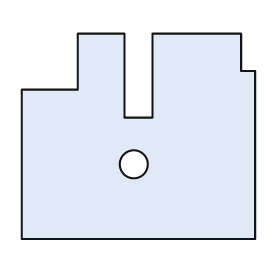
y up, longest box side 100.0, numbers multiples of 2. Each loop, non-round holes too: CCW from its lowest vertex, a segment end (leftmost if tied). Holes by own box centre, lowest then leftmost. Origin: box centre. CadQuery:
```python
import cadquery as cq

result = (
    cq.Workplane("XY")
    .moveTo(-50.0, -44.0)
    .lineTo(50.0, -44.0)
    .lineTo(50.0, 28.0)
    .lineTo(44.0, 28.0)
    .lineTo(44.0, 44.0)
    .lineTo(6.0, 44.0)
    .lineTo(6.0, 8.0)
    .lineTo(-6.0, 8.0)
    .lineTo(-6.0, 44.0)
    .lineTo(-26.0, 44.0)
    .lineTo(-26.0, 20.0)
    .lineTo(-50.0, 20.0)
    .close()
    .moveTo(-2.0, -12.0)
    .circle(6.0)
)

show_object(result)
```